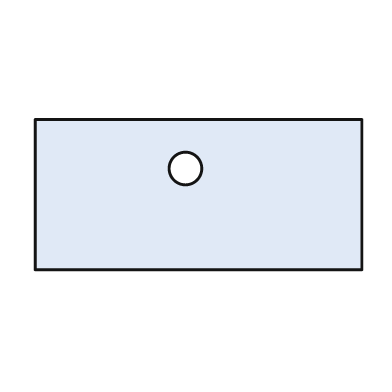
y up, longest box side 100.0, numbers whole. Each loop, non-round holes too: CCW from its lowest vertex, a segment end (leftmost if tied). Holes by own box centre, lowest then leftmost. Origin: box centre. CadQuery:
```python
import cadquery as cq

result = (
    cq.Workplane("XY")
    .moveTo(-50.0, -23.0)
    .lineTo(50.0, -23.0)
    .lineTo(50.0, 23.0)
    .lineTo(-50.0, 23.0)
    .close()
    .moveTo(-4.0, 8.0)
    .circle(5.0)
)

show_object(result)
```